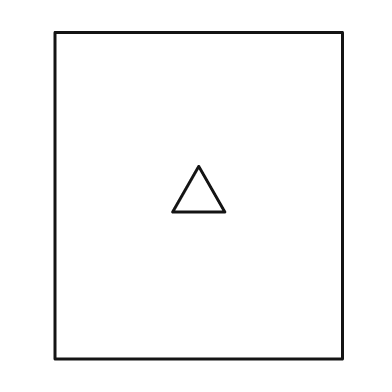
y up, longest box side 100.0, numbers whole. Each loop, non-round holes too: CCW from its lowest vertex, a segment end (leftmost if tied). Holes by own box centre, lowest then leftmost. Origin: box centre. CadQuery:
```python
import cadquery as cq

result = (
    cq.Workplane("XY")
    .moveTo(-44.0, -50.0)
    .lineTo(44.0, -50.0)
    .lineTo(44.0, 50.0)
    .lineTo(-44.0, 50.0)
    .close()
    .moveTo(-8.0, -5.0)
    .lineTo(8.0, -5.0)
    .lineTo(0.0, 9.0)
    .close()
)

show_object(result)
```